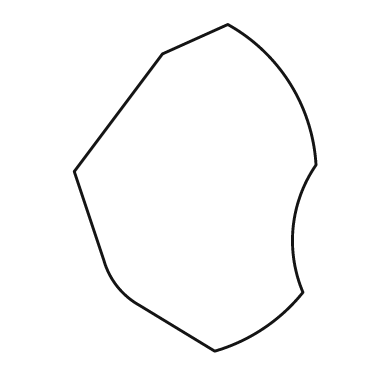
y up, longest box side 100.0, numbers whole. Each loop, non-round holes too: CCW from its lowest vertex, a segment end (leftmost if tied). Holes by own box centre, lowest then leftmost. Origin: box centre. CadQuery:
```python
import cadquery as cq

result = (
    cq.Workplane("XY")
    .moveTo(6.0, -50.0)
    .threePointArc((21.0, -43.0), (33.0, -32.0))
    .threePointArc((30.0, -12.0), (37.0, 7.0))
    .threePointArc((29.0, 32.0), (10.0, 50.0))
    .lineTo(-10.0, 41.0)
    .lineTo(-37.0, 5.0)
    .lineTo(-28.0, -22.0)
    .threePointArc((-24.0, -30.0), (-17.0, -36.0))
    .close()
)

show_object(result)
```